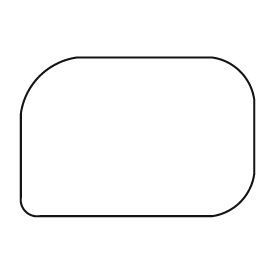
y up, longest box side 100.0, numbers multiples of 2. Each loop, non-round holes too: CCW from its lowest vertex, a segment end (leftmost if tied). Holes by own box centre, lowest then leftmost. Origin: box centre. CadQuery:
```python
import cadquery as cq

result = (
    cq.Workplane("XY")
    .moveTo(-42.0, -34.0)
    .lineTo(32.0, -34.0)
    .threePointArc((44.0, -28.0), (50.0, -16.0))
    .lineTo(50.0, 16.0)
    .threePointArc((44.0, 28.0), (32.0, 34.0))
    .lineTo(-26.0, 34.0)
    .threePointArc((-42.0, 26.0), (-50.0, 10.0))
    .lineTo(-50.0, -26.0)
    .threePointArc((-48.0, -32.0), (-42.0, -34.0))
    .close()
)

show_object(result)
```